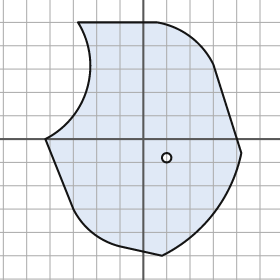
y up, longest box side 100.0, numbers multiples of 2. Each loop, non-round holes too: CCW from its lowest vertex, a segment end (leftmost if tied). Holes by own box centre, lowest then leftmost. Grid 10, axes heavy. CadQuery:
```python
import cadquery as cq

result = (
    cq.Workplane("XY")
    .moveTo(8.0, -50.0)
    .threePointArc((30.0, -32.0), (42.0, -6.0))
    .lineTo(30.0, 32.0)
    .threePointArc((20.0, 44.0), (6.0, 50.0))
    .lineTo(-28.0, 50.0)
    .threePointArc((-24.0, 22.0), (-42.0, 0.0))
    .lineTo(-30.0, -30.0)
    .threePointArc((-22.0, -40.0), (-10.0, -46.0))
    .close()
    .moveTo(10.0, -8.0)
    .circle(2.0)
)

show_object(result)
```